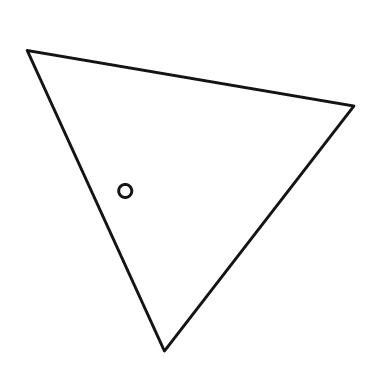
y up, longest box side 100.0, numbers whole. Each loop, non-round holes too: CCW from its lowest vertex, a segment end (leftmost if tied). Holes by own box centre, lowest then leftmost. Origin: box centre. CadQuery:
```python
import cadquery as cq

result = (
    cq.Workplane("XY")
    .moveTo(-8.0, -46.0)
    .lineTo(50.0, 29.0)
    .lineTo(-50.0, 46.0)
    .close()
    .moveTo(-20.0, 3.0)
    .circle(2.0)
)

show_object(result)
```